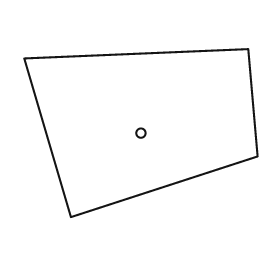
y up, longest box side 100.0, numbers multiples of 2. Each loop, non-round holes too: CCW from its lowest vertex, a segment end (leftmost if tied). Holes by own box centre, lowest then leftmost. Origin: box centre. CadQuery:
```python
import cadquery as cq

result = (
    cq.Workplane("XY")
    .moveTo(-30.0, -36.0)
    .lineTo(50.0, -10.0)
    .lineTo(46.0, 36.0)
    .lineTo(-50.0, 32.0)
    .close()
    .moveTo(0.0, 0.0)
    .circle(2.0)
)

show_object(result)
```